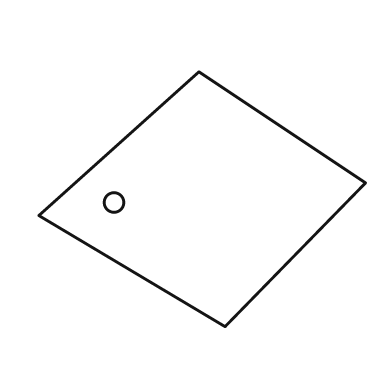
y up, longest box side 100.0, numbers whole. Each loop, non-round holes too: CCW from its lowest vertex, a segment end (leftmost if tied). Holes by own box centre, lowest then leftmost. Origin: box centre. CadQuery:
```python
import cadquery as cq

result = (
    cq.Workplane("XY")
    .moveTo(7.0, -39.0)
    .lineTo(50.0, 5.0)
    .lineTo(-1.0, 39.0)
    .lineTo(-50.0, -5.0)
    .close()
    .moveTo(-27.0, -1.0)
    .circle(3.0)
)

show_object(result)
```